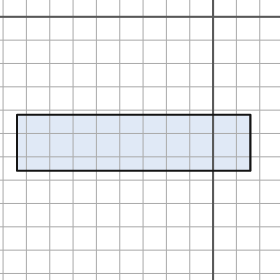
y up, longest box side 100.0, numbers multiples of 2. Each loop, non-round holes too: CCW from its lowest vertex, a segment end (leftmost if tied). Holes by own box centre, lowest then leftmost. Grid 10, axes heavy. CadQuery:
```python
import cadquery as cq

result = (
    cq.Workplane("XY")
    .moveTo(-84.0, -66.0)
    .lineTo(16.0, -66.0)
    .lineTo(16.0, -42.0)
    .lineTo(-84.0, -42.0)
    .close()
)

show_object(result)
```